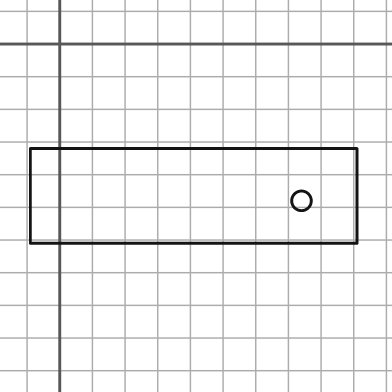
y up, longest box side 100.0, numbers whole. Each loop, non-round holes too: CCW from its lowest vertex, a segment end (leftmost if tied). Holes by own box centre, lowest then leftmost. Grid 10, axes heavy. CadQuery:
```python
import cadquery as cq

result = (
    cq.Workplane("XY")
    .moveTo(-9.0, -61.0)
    .lineTo(91.0, -61.0)
    .lineTo(91.0, -32.0)
    .lineTo(-9.0, -32.0)
    .close()
    .moveTo(74.0, -48.0)
    .circle(3.0)
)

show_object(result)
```